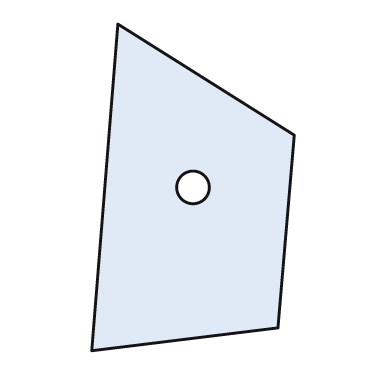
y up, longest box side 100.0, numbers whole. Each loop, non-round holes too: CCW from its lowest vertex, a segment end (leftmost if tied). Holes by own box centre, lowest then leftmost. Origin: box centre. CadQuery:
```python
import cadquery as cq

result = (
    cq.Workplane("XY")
    .moveTo(-31.0, -50.0)
    .lineTo(26.0, -43.0)
    .lineTo(31.0, 16.0)
    .lineTo(-23.0, 50.0)
    .close()
    .moveTo(0.0, 0.0)
    .circle(5.0)
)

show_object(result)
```